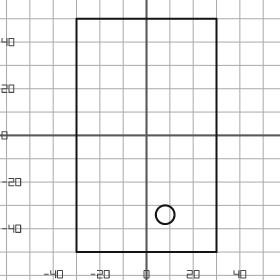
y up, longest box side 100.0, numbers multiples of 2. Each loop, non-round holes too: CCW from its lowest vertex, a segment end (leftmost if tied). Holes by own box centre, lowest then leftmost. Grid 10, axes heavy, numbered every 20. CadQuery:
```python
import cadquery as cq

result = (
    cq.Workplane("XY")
    .moveTo(-30.0, -50.0)
    .lineTo(30.0, -50.0)
    .lineTo(30.0, 50.0)
    .lineTo(-30.0, 50.0)
    .close()
    .moveTo(8.0, -34.0)
    .circle(4.0)
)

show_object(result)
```